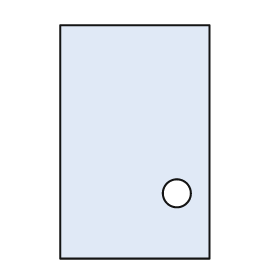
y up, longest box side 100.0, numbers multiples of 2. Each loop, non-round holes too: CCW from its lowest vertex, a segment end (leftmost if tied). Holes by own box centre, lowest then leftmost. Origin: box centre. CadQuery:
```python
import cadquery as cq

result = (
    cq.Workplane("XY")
    .moveTo(-32.0, -50.0)
    .lineTo(32.0, -50.0)
    .lineTo(32.0, 50.0)
    .lineTo(-32.0, 50.0)
    .close()
    .moveTo(18.0, -22.0)
    .circle(6.0)
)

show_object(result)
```